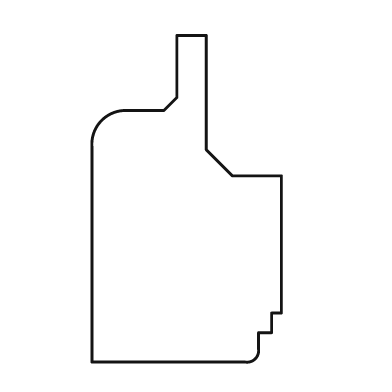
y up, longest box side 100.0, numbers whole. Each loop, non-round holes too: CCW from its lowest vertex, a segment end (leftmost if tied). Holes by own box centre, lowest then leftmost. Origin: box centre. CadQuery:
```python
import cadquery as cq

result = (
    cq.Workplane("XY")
    .moveTo(-29.0, -50.0)
    .lineTo(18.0, -50.0)
    .threePointArc((21.0, -49.0), (22.0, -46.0))
    .lineTo(22.0, -41.0)
    .lineTo(26.0, -41.0)
    .lineTo(26.0, -35.0)
    .lineTo(29.0, -35.0)
    .lineTo(29.0, 7.0)
    .lineTo(14.0, 7.0)
    .lineTo(6.0, 15.0)
    .lineTo(6.0, 50.0)
    .lineTo(-3.0, 50.0)
    .lineTo(-3.0, 31.0)
    .lineTo(-7.0, 27.0)
    .lineTo(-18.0, 27.0)
    .threePointArc((-26.0, 24.0), (-29.0, 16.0))
    .close()
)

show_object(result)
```